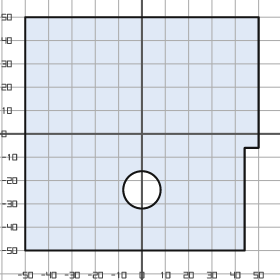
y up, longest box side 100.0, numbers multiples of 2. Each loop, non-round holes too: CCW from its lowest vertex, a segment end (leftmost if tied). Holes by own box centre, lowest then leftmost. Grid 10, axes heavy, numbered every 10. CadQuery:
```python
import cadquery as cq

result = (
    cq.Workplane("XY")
    .moveTo(-50.0, -50.0)
    .lineTo(44.0, -50.0)
    .lineTo(44.0, -6.0)
    .lineTo(50.0, -6.0)
    .lineTo(50.0, 50.0)
    .lineTo(-50.0, 50.0)
    .close()
    .moveTo(0.0, -24.0)
    .circle(8.0)
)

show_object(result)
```